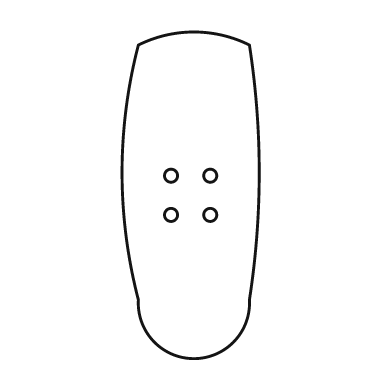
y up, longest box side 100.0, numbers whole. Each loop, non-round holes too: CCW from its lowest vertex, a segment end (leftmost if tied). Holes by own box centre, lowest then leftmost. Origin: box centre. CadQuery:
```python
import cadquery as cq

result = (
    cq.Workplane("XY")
    .moveTo(-16.0, -32.0)
    .threePointArc((1.0, -50.0), (18.0, -32.0))
    .threePointArc((21.0, 7.0), (18.0, 46.0))
    .threePointArc((1.0, 50.0), (-16.0, 46.0))
    .threePointArc((-21.0, 7.0), (-16.0, -32.0))
    .close()
    .moveTo(-6.0, -6.0)
    .circle(2.0)
    .moveTo(6.0, -6.0)
    .circle(2.0)
    .moveTo(-6.0, 6.0)
    .circle(2.0)
    .moveTo(6.0, 6.0)
    .circle(2.0)
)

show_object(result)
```